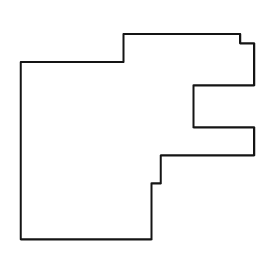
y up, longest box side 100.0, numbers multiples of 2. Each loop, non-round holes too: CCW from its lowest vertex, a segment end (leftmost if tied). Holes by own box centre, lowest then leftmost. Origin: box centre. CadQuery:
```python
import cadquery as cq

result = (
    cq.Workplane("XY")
    .moveTo(-50.0, -44.0)
    .lineTo(6.0, -44.0)
    .lineTo(6.0, -20.0)
    .lineTo(10.0, -20.0)
    .lineTo(10.0, -8.0)
    .lineTo(50.0, -8.0)
    .lineTo(50.0, 4.0)
    .lineTo(24.0, 4.0)
    .lineTo(24.0, 22.0)
    .lineTo(50.0, 22.0)
    .lineTo(50.0, 40.0)
    .lineTo(44.0, 40.0)
    .lineTo(44.0, 44.0)
    .lineTo(-6.0, 44.0)
    .lineTo(-6.0, 32.0)
    .lineTo(-50.0, 32.0)
    .close()
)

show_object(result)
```